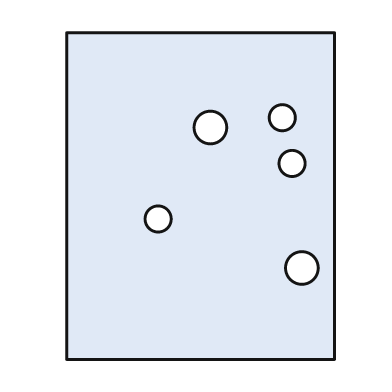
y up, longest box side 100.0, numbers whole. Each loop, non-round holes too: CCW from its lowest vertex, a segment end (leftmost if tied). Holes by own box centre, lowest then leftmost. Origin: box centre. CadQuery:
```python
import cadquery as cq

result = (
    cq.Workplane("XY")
    .moveTo(-41.0, -50.0)
    .lineTo(41.0, -50.0)
    .lineTo(41.0, 50.0)
    .lineTo(-41.0, 50.0)
    .close()
    .moveTo(31.0, -22.0)
    .circle(5.0)
    .moveTo(-13.0, -7.0)
    .circle(4.0)
    .moveTo(28.0, 10.0)
    .circle(4.0)
    .moveTo(3.0, 21.0)
    .circle(5.0)
    .moveTo(25.0, 24.0)
    .circle(4.0)
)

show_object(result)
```